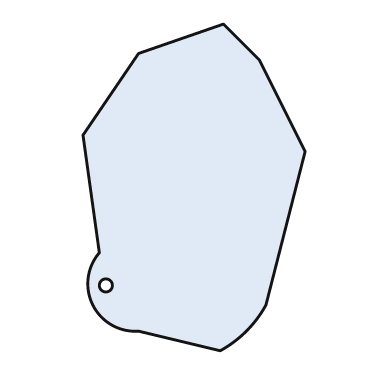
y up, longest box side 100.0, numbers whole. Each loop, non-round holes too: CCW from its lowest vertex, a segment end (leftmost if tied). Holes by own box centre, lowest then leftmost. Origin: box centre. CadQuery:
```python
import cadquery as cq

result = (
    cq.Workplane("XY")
    .moveTo(8.0, -50.0)
    .threePointArc((16.0, -44.0), (22.0, -36.0))
    .lineTo(34.0, 11.0)
    .lineTo(20.0, 39.0)
    .lineTo(9.0, 50.0)
    .lineTo(-17.0, 41.0)
    .lineTo(-34.0, 16.0)
    .lineTo(-29.0, -20.0)
    .threePointArc((-31.0, -36.0), (-17.0, -44.0))
    .close()
    .moveTo(-27.0, -30.0)
    .circle(2.0)
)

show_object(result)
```